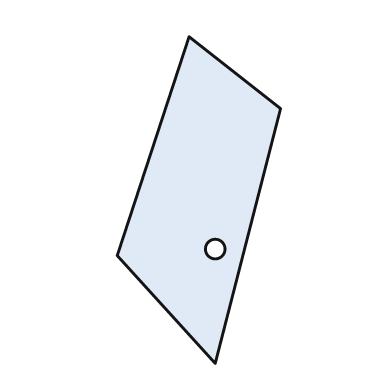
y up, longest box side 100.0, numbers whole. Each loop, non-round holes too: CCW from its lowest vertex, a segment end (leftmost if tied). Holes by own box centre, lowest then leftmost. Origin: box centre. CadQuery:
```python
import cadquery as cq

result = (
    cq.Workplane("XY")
    .moveTo(5.0, -50.0)
    .lineTo(25.0, 28.0)
    .lineTo(-3.0, 50.0)
    .lineTo(-25.0, -17.0)
    .close()
    .moveTo(5.0, -15.0)
    .circle(3.0)
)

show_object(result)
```